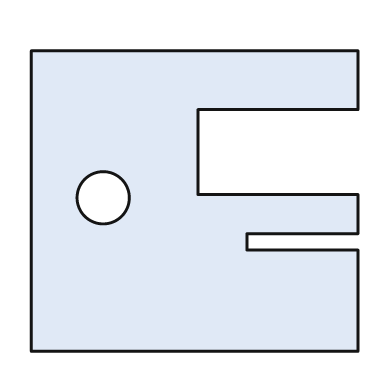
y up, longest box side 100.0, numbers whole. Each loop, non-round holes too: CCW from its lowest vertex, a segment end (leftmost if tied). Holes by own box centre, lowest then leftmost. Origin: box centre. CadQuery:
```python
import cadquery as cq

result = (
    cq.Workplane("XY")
    .moveTo(-50.0, -46.0)
    .lineTo(50.0, -46.0)
    .lineTo(50.0, -15.0)
    .lineTo(16.0, -15.0)
    .lineTo(16.0, -10.0)
    .lineTo(50.0, -10.0)
    .lineTo(50.0, 2.0)
    .lineTo(1.0, 2.0)
    .lineTo(1.0, 28.0)
    .lineTo(50.0, 28.0)
    .lineTo(50.0, 46.0)
    .lineTo(-50.0, 46.0)
    .close()
    .moveTo(-28.0, 1.0)
    .circle(8.0)
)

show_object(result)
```